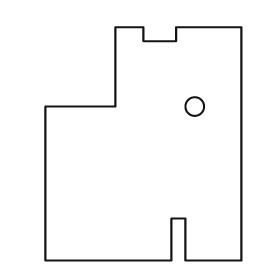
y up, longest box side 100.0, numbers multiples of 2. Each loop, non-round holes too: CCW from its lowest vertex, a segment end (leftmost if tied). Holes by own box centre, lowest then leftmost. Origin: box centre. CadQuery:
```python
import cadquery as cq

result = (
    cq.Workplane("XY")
    .moveTo(-42.0, -50.0)
    .lineTo(12.0, -50.0)
    .lineTo(12.0, -32.0)
    .lineTo(18.0, -32.0)
    .lineTo(18.0, -50.0)
    .lineTo(42.0, -50.0)
    .lineTo(42.0, 50.0)
    .lineTo(14.0, 50.0)
    .lineTo(14.0, 44.0)
    .lineTo(0.0, 44.0)
    .lineTo(0.0, 50.0)
    .lineTo(-12.0, 50.0)
    .lineTo(-12.0, 16.0)
    .lineTo(-42.0, 16.0)
    .close()
    .moveTo(22.0, 16.0)
    .circle(4.0)
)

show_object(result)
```